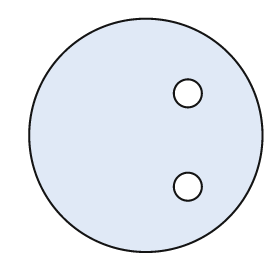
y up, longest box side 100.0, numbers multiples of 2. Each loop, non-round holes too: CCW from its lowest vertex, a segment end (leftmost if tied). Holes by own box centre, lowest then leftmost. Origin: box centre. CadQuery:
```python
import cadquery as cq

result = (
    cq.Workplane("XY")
    .moveTo(0.0, 0.0)
    .circle(50.0)
    .moveTo(18.0, -22.0)
    .circle(6.0)
    .moveTo(18.0, 18.0)
    .circle(6.0)
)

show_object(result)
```